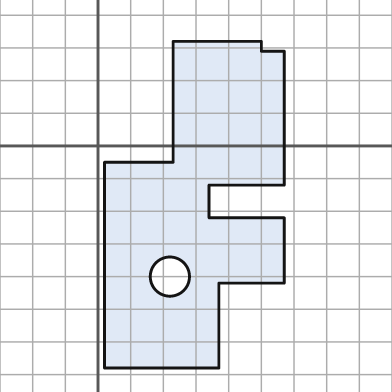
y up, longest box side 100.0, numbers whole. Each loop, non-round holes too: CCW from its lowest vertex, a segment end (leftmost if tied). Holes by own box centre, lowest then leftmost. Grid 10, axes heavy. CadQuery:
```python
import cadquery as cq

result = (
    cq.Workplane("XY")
    .moveTo(2.0, -68.0)
    .lineTo(37.0, -68.0)
    .lineTo(37.0, -42.0)
    .lineTo(57.0, -42.0)
    .lineTo(57.0, -22.0)
    .lineTo(34.0, -22.0)
    .lineTo(34.0, -12.0)
    .lineTo(57.0, -12.0)
    .lineTo(57.0, 29.0)
    .lineTo(50.0, 29.0)
    .lineTo(50.0, 32.0)
    .lineTo(23.0, 32.0)
    .lineTo(23.0, -5.0)
    .lineTo(2.0, -5.0)
    .close()
    .moveTo(22.0, -40.0)
    .circle(6.0)
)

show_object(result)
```